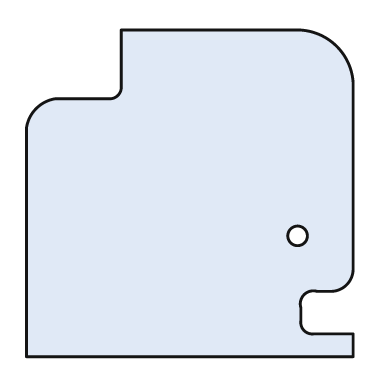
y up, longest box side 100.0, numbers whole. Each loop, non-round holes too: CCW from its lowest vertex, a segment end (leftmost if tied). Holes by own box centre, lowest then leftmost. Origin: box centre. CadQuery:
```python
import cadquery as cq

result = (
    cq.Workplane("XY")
    .moveTo(-50.0, -50.0)
    .lineTo(50.0, -50.0)
    .lineTo(50.0, -43.0)
    .lineTo(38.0, -43.0)
    .threePointArc((35.0, -42.0), (34.0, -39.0))
    .lineTo(34.0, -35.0)
    .threePointArc((35.0, -31.0), (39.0, -30.0))
    .lineTo(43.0, -30.0)
    .threePointArc((48.0, -28.0), (50.0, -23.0))
    .lineTo(50.0, 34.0)
    .threePointArc((45.0, 45.0), (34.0, 50.0))
    .lineTo(-21.0, 50.0)
    .lineTo(-21.0, 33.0)
    .threePointArc((-22.0, 30.0), (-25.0, 29.0))
    .lineTo(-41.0, 29.0)
    .threePointArc((-47.0, 26.0), (-50.0, 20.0))
    .close()
    .moveTo(33.0, -13.0)
    .circle(3.0)
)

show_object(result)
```